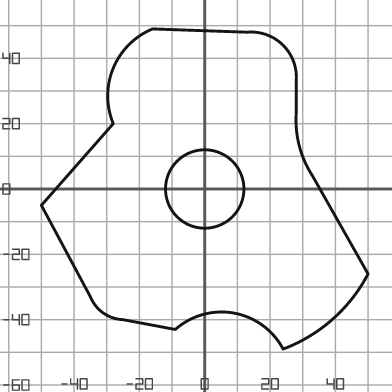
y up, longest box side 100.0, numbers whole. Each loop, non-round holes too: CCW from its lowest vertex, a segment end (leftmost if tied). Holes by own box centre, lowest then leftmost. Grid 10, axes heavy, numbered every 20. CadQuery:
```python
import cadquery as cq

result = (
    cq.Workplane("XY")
    .moveTo(24.0, -49.0)
    .threePointArc((39.0, -40.0), (50.0, -26.0))
    .lineTo(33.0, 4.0)
    .threePointArc((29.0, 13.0), (28.0, 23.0))
    .lineTo(28.0, 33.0)
    .threePointArc((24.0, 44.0), (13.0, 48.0))
    .lineTo(-16.0, 49.0)
    .threePointArc((-28.0, 37.0), (-28.0, 20.0))
    .lineTo(-50.0, -5.0)
    .lineTo(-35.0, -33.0)
    .threePointArc((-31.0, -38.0), (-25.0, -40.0))
    .lineTo(-9.0, -43.0)
    .threePointArc((9.0, -38.0), (24.0, -49.0))
    .close()
    .moveTo(0.0, 0.0)
    .circle(12.0)
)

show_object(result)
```